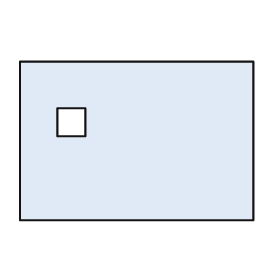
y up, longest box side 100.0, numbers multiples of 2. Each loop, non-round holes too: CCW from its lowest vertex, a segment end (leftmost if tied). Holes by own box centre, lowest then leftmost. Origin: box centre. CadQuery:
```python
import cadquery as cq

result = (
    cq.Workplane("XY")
    .moveTo(-50.0, -34.0)
    .lineTo(50.0, -34.0)
    .lineTo(50.0, 34.0)
    .lineTo(-50.0, 34.0)
    .close()
    .moveTo(-34.0, 2.0)
    .lineTo(-22.0, 2.0)
    .lineTo(-22.0, 14.0)
    .lineTo(-34.0, 14.0)
    .close()
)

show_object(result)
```